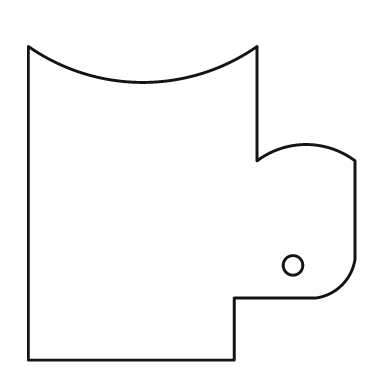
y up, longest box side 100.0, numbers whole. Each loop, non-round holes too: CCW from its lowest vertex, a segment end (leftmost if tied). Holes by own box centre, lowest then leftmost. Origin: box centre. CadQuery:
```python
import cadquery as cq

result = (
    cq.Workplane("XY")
    .moveTo(-50.0, -48.0)
    .lineTo(13.0, -48.0)
    .lineTo(13.0, -29.0)
    .lineTo(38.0, -29.0)
    .threePointArc((46.0, -25.0), (50.0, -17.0))
    .lineTo(50.0, 13.0)
    .threePointArc((35.0, 18.0), (20.0, 13.0))
    .lineTo(20.0, 48.0)
    .threePointArc((-15.0, 37.0), (-50.0, 48.0))
    .close()
    .moveTo(31.0, -19.0)
    .circle(3.0)
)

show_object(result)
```